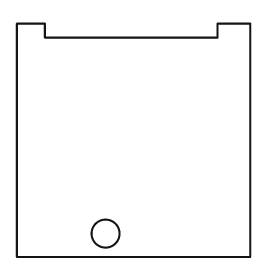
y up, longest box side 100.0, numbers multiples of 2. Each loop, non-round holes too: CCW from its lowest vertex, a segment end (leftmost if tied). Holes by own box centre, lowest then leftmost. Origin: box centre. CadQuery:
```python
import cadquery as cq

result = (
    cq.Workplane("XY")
    .moveTo(-50.0, -50.0)
    .lineTo(50.0, -50.0)
    .lineTo(50.0, 50.0)
    .lineTo(36.0, 50.0)
    .lineTo(36.0, 44.0)
    .lineTo(-38.0, 44.0)
    .lineTo(-38.0, 50.0)
    .lineTo(-50.0, 50.0)
    .close()
    .moveTo(-12.0, -40.0)
    .circle(6.0)
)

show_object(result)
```